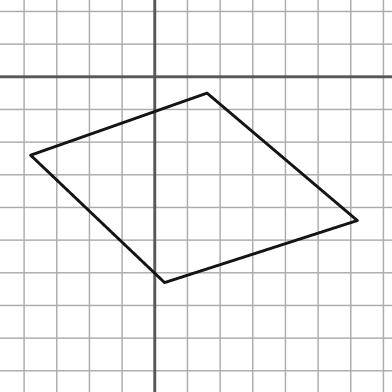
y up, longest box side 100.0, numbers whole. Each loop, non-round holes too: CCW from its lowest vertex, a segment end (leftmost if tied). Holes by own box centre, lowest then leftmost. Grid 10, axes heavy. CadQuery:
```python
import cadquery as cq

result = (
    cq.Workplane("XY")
    .moveTo(3.0, -63.0)
    .lineTo(62.0, -44.0)
    .lineTo(16.0, -5.0)
    .lineTo(-38.0, -24.0)
    .close()
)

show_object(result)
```